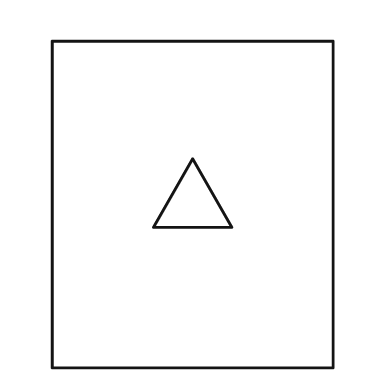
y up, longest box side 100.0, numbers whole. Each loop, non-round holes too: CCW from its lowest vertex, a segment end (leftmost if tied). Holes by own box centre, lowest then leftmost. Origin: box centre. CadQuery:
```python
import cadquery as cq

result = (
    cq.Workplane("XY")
    .moveTo(-43.0, -50.0)
    .lineTo(43.0, -50.0)
    .lineTo(43.0, 50.0)
    .lineTo(-43.0, 50.0)
    .close()
    .moveTo(-12.0, -7.0)
    .lineTo(12.0, -7.0)
    .lineTo(0.0, 14.0)
    .close()
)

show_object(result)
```